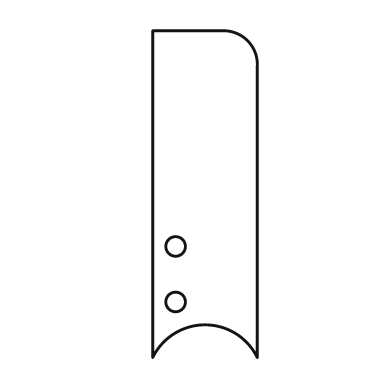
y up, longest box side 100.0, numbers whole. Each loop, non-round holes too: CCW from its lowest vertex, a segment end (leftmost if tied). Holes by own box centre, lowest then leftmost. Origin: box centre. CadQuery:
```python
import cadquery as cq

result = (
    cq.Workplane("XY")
    .moveTo(-16.0, -50.0)
    .threePointArc((0.0, -40.0), (16.0, -50.0))
    .lineTo(16.0, 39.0)
    .threePointArc((13.0, 47.0), (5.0, 50.0))
    .lineTo(-16.0, 50.0)
    .close()
    .moveTo(-9.0, -33.0)
    .circle(3.0)
    .moveTo(-9.0, -16.0)
    .circle(3.0)
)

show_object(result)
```